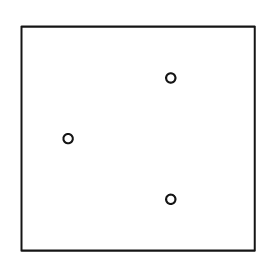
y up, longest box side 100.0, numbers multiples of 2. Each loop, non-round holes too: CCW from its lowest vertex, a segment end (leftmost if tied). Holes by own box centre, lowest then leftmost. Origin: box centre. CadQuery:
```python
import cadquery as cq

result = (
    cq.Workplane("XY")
    .moveTo(-50.0, -48.0)
    .lineTo(50.0, -48.0)
    .lineTo(50.0, 48.0)
    .lineTo(-50.0, 48.0)
    .close()
    .moveTo(14.0, -26.0)
    .circle(2.0)
    .moveTo(-30.0, 0.0)
    .circle(2.0)
    .moveTo(14.0, 26.0)
    .circle(2.0)
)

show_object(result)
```